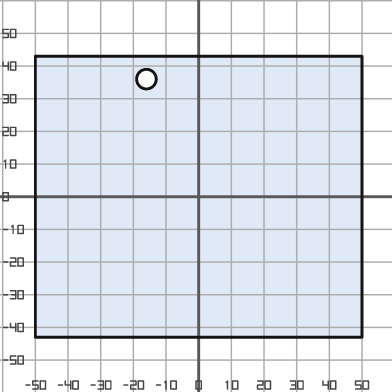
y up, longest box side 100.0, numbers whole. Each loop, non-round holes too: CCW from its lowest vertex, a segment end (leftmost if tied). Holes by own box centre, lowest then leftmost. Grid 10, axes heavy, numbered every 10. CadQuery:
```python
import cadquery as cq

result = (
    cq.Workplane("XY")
    .moveTo(-50.0, -43.0)
    .lineTo(50.0, -43.0)
    .lineTo(50.0, 43.0)
    .lineTo(-50.0, 43.0)
    .close()
    .moveTo(-16.0, 36.0)
    .circle(3.0)
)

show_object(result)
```